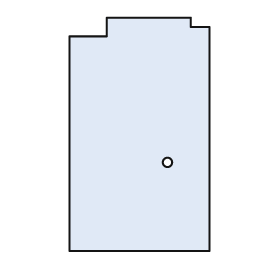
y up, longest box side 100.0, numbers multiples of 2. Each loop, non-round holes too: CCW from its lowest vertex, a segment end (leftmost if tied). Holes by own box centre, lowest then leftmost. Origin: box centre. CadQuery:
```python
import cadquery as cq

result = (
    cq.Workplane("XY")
    .moveTo(-30.0, -50.0)
    .lineTo(30.0, -50.0)
    .lineTo(30.0, 46.0)
    .lineTo(22.0, 46.0)
    .lineTo(22.0, 50.0)
    .lineTo(-14.0, 50.0)
    .lineTo(-14.0, 42.0)
    .lineTo(-30.0, 42.0)
    .close()
    .moveTo(12.0, -12.0)
    .circle(2.0)
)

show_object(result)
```